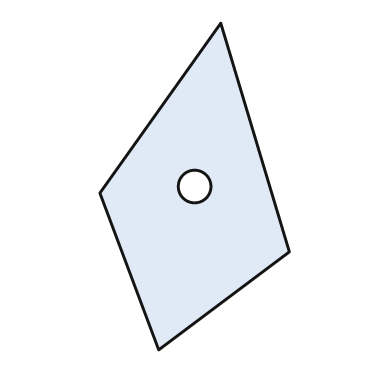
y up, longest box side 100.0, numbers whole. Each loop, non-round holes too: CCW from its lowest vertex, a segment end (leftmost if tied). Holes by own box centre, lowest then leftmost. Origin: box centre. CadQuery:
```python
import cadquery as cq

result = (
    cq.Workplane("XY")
    .moveTo(-11.0, -50.0)
    .lineTo(29.0, -20.0)
    .lineTo(8.0, 50.0)
    .lineTo(-29.0, -2.0)
    .close()
    .moveTo(0.0, 0.0)
    .circle(5.0)
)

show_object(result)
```